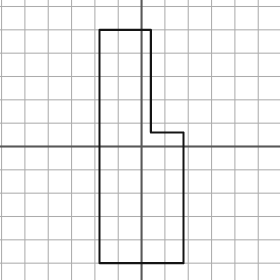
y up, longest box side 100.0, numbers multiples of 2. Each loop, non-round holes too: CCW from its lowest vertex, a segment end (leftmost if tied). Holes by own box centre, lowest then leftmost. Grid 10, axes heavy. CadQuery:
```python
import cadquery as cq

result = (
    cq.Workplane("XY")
    .moveTo(-18.0, -50.0)
    .lineTo(18.0, -50.0)
    .lineTo(18.0, 6.0)
    .lineTo(4.0, 6.0)
    .lineTo(4.0, 50.0)
    .lineTo(-18.0, 50.0)
    .close()
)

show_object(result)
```